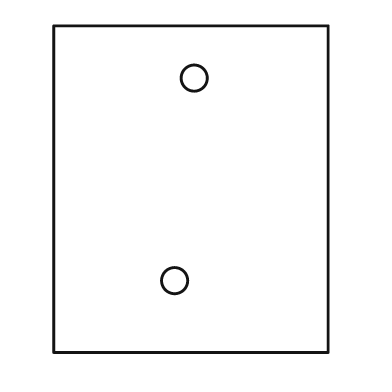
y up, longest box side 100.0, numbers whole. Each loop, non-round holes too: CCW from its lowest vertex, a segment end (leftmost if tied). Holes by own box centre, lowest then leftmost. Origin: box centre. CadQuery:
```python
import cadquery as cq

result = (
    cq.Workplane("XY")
    .moveTo(-42.0, -50.0)
    .lineTo(42.0, -50.0)
    .lineTo(42.0, 50.0)
    .lineTo(-42.0, 50.0)
    .close()
    .moveTo(-5.0, -28.0)
    .circle(4.0)
    .moveTo(1.0, 34.0)
    .circle(4.0)
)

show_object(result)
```